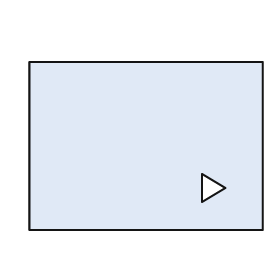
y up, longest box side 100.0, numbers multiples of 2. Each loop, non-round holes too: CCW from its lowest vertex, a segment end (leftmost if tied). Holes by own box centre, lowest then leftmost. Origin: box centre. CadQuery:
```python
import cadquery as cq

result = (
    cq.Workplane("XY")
    .moveTo(-50.0, -36.0)
    .lineTo(50.0, -36.0)
    .lineTo(50.0, 36.0)
    .lineTo(-50.0, 36.0)
    .close()
    .moveTo(24.0, -24.0)
    .lineTo(34.0, -18.0)
    .lineTo(24.0, -12.0)
    .close()
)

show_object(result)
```